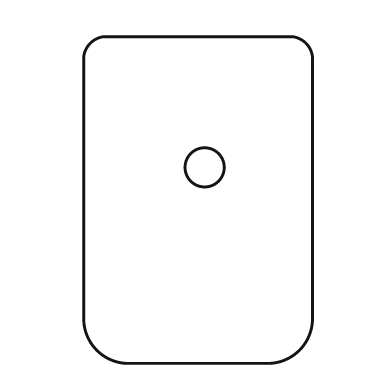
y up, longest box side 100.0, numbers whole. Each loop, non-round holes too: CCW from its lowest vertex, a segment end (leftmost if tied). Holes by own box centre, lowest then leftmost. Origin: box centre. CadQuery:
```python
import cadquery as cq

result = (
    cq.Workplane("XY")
    .moveTo(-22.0, -50.0)
    .lineTo(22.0, -50.0)
    .threePointArc((31.0, -46.0), (35.0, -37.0))
    .lineTo(35.0, 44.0)
    .threePointArc((33.0, 48.0), (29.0, 50.0))
    .lineTo(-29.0, 50.0)
    .threePointArc((-33.0, 48.0), (-35.0, 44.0))
    .lineTo(-35.0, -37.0)
    .threePointArc((-31.0, -46.0), (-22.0, -50.0))
    .close()
    .moveTo(2.0, 10.0)
    .circle(6.0)
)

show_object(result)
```